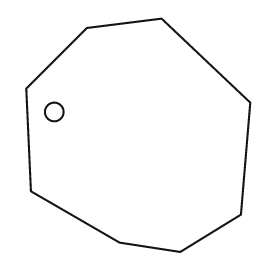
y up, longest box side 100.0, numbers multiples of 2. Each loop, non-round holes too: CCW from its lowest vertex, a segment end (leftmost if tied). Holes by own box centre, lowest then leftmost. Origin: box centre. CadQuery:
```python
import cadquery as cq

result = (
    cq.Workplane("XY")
    .moveTo(18.0, -50.0)
    .lineTo(44.0, -34.0)
    .lineTo(48.0, 14.0)
    .lineTo(10.0, 50.0)
    .lineTo(-22.0, 46.0)
    .lineTo(-48.0, 20.0)
    .lineTo(-46.0, -24.0)
    .lineTo(-8.0, -46.0)
    .close()
    .moveTo(-36.0, 10.0)
    .circle(4.0)
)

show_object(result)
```